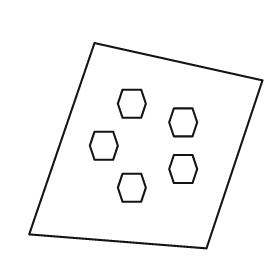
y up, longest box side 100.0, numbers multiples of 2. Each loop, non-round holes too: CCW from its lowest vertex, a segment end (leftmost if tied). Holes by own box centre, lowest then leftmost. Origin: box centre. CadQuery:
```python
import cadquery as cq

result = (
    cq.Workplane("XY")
    .moveTo(26.0, -44.0)
    .lineTo(50.0, 28.0)
    .lineTo(-22.0, 44.0)
    .lineTo(-50.0, -38.0)
    .close()
    .moveTo(-10.0, -24.0)
    .lineTo(-2.0, -24.0)
    .lineTo(0.0, -18.0)
    .lineTo(-2.0, -12.0)
    .lineTo(-10.0, -12.0)
    .lineTo(-12.0, -18.0)
    .close()
    .moveTo(12.0, -16.0)
    .lineTo(20.0, -16.0)
    .lineTo(22.0, -10.0)
    .lineTo(20.0, -4.0)
    .lineTo(12.0, -4.0)
    .lineTo(10.0, -10.0)
    .close()
    .moveTo(-22.0, -6.0)
    .lineTo(-14.0, -6.0)
    .lineTo(-12.0, 0.0)
    .lineTo(-14.0, 6.0)
    .lineTo(-22.0, 6.0)
    .lineTo(-24.0, 0.0)
    .close()
    .moveTo(12.0, 4.0)
    .lineTo(20.0, 4.0)
    .lineTo(22.0, 10.0)
    .lineTo(20.0, 16.0)
    .lineTo(12.0, 16.0)
    .lineTo(10.0, 10.0)
    .close()
    .moveTo(-10.0, 12.0)
    .lineTo(-2.0, 12.0)
    .lineTo(0.0, 18.0)
    .lineTo(-2.0, 24.0)
    .lineTo(-10.0, 24.0)
    .lineTo(-12.0, 18.0)
    .close()
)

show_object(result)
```